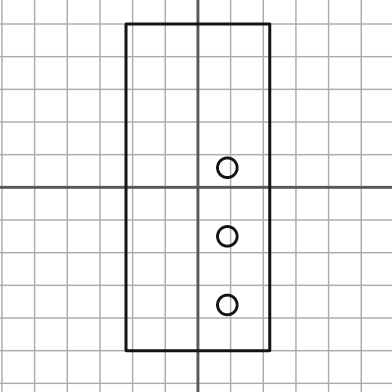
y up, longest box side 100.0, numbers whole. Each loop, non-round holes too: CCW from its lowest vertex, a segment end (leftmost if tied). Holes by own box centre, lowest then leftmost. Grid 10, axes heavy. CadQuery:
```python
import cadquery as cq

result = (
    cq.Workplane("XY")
    .moveTo(-22.0, -50.0)
    .lineTo(22.0, -50.0)
    .lineTo(22.0, 50.0)
    .lineTo(-22.0, 50.0)
    .close()
    .moveTo(9.0, -36.0)
    .circle(3.0)
    .moveTo(9.0, -15.0)
    .circle(3.0)
    .moveTo(9.0, 6.0)
    .circle(3.0)
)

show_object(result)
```